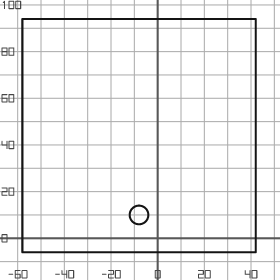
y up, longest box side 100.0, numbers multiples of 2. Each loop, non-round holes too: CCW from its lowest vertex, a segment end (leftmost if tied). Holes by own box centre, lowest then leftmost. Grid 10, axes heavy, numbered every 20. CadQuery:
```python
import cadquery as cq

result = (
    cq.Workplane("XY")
    .moveTo(-58.0, -6.0)
    .lineTo(42.0, -6.0)
    .lineTo(42.0, 94.0)
    .lineTo(-58.0, 94.0)
    .close()
    .moveTo(-8.0, 10.0)
    .circle(4.0)
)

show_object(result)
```